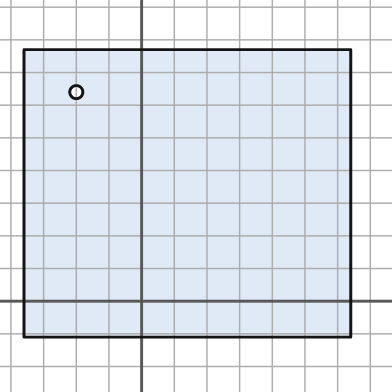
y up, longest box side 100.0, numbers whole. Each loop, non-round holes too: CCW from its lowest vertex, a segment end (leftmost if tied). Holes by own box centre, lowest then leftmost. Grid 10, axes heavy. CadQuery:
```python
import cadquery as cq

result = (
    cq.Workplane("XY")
    .moveTo(-36.0, -11.0)
    .lineTo(64.0, -11.0)
    .lineTo(64.0, 77.0)
    .lineTo(-36.0, 77.0)
    .close()
    .moveTo(-20.0, 64.0)
    .circle(2.0)
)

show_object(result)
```